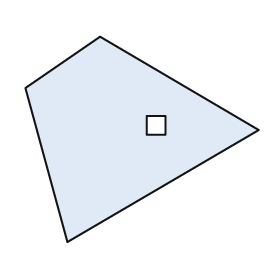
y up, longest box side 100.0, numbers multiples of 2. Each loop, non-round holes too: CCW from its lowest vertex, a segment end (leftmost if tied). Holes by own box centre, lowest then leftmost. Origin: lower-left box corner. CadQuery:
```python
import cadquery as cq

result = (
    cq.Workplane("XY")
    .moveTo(18.0, 0.0)
    .lineTo(100.0, 48.0)
    .lineTo(32.0, 88.0)
    .lineTo(0.0, 66.0)
    .close()
    .moveTo(52.0, 46.0)
    .lineTo(60.0, 46.0)
    .lineTo(60.0, 54.0)
    .lineTo(52.0, 54.0)
    .close()
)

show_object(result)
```